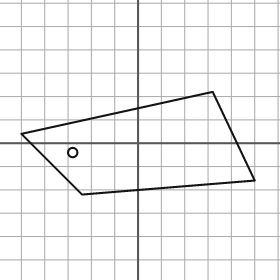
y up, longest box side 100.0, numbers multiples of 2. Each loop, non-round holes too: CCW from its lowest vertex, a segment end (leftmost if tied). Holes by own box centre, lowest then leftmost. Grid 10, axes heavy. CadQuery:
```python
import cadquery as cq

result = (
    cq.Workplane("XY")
    .moveTo(-24.0, -22.0)
    .lineTo(50.0, -16.0)
    .lineTo(32.0, 22.0)
    .lineTo(-50.0, 4.0)
    .close()
    .moveTo(-28.0, -4.0)
    .circle(2.0)
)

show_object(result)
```